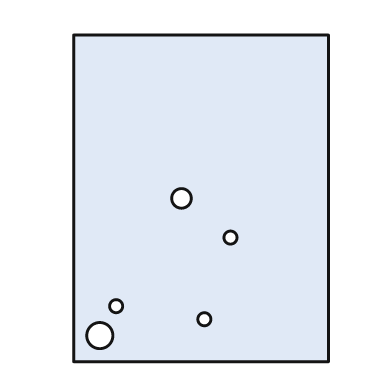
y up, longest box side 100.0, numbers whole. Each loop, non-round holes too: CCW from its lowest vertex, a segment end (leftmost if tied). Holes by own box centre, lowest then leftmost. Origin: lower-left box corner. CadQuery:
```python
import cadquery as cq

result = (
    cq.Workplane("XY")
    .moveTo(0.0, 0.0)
    .lineTo(78.0, 0.0)
    .lineTo(78.0, 100.0)
    .lineTo(0.0, 100.0)
    .close()
    .moveTo(8.0, 8.0)
    .circle(4.0)
    .moveTo(40.0, 13.0)
    .circle(2.0)
    .moveTo(13.0, 17.0)
    .circle(2.0)
    .moveTo(48.0, 38.0)
    .circle(2.0)
    .moveTo(33.0, 50.0)
    .circle(3.0)
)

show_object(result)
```